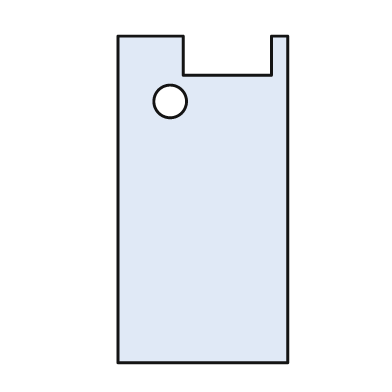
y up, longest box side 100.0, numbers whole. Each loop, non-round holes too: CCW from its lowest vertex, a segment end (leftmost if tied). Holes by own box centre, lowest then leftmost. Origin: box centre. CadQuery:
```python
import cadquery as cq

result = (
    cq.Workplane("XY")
    .moveTo(-26.0, -50.0)
    .lineTo(26.0, -50.0)
    .lineTo(26.0, 50.0)
    .lineTo(21.0, 50.0)
    .lineTo(21.0, 38.0)
    .lineTo(-6.0, 38.0)
    .lineTo(-6.0, 50.0)
    .lineTo(-26.0, 50.0)
    .close()
    .moveTo(-10.0, 30.0)
    .circle(5.0)
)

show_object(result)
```